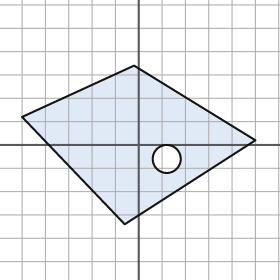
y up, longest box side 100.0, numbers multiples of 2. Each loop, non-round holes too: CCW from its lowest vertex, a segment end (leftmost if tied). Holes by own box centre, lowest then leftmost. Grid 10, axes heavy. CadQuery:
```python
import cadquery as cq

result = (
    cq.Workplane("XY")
    .moveTo(-6.0, -34.0)
    .lineTo(50.0, 2.0)
    .lineTo(-2.0, 34.0)
    .lineTo(-50.0, 12.0)
    .close()
    .moveTo(12.0, -6.0)
    .circle(6.0)
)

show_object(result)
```